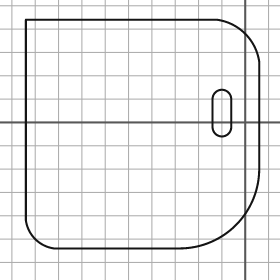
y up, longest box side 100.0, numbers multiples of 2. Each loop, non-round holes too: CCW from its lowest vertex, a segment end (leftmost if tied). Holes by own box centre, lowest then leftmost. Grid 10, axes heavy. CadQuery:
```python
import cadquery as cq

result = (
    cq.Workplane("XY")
    .moveTo(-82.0, -54.0)
    .lineTo(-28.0, -54.0)
    .threePointArc((-4.0, -44.0), (6.0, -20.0))
    .lineTo(6.0, 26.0)
    .threePointArc((0.0, 38.0), (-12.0, 44.0))
    .lineTo(-94.0, 44.0)
    .lineTo(-94.0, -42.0)
    .threePointArc((-90.0, -50.0), (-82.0, -54.0))
    .close()
    .moveTo(-14.0, -2.0)
    .threePointArc((-10.0, -6.0), (-6.0, -2.0))
    .lineTo(-6.0, 10.0)
    .threePointArc((-10.0, 14.0), (-14.0, 10.0))
    .close()
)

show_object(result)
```